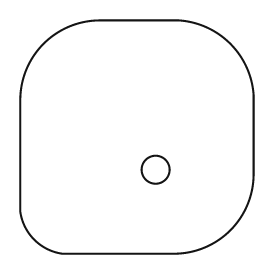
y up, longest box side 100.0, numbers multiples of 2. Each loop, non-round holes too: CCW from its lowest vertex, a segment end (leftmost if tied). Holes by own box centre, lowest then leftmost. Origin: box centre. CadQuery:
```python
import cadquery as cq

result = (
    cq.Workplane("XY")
    .moveTo(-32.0, -50.0)
    .lineTo(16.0, -50.0)
    .threePointArc((40.0, -40.0), (50.0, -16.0))
    .lineTo(50.0, 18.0)
    .threePointArc((40.0, 40.0), (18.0, 50.0))
    .lineTo(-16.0, 50.0)
    .threePointArc((-40.0, 40.0), (-50.0, 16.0))
    .lineTo(-50.0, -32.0)
    .threePointArc((-44.0, -44.0), (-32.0, -50.0))
    .close()
    .moveTo(8.0, -14.0)
    .circle(6.0)
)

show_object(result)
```